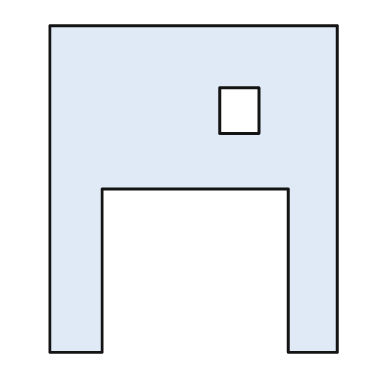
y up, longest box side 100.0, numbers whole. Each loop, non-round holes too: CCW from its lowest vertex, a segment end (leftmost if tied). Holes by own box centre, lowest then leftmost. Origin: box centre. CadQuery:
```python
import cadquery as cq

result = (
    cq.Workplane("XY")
    .moveTo(-44.0, -50.0)
    .lineTo(-28.0, -50.0)
    .lineTo(-28.0, 0.0)
    .lineTo(29.0, 0.0)
    .lineTo(29.0, -50.0)
    .lineTo(44.0, -50.0)
    .lineTo(44.0, 50.0)
    .lineTo(-44.0, 50.0)
    .close()
    .moveTo(8.0, 17.0)
    .lineTo(20.0, 17.0)
    .lineTo(20.0, 31.0)
    .lineTo(8.0, 31.0)
    .close()
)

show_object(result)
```